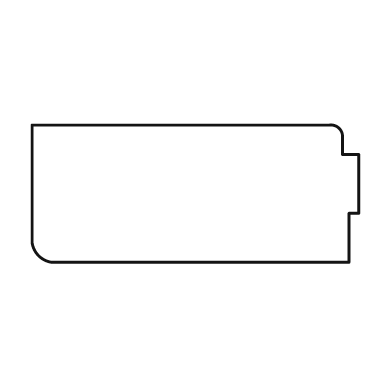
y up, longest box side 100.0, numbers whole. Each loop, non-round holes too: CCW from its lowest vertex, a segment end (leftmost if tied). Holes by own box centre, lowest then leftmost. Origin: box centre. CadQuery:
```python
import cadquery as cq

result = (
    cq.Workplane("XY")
    .moveTo(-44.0, -21.0)
    .lineTo(47.0, -21.0)
    .lineTo(47.0, -6.0)
    .lineTo(50.0, -6.0)
    .lineTo(50.0, 12.0)
    .lineTo(45.0, 12.0)
    .lineTo(45.0, 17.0)
    .threePointArc((44.0, 20.0), (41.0, 21.0))
    .lineTo(-50.0, 21.0)
    .lineTo(-50.0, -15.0)
    .threePointArc((-48.0, -19.0), (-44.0, -21.0))
    .close()
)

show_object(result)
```